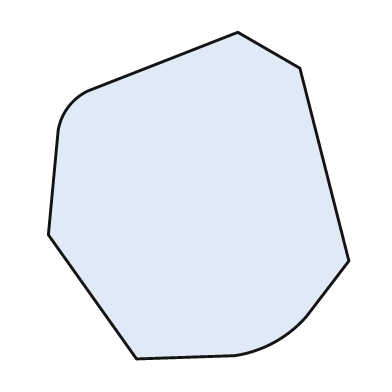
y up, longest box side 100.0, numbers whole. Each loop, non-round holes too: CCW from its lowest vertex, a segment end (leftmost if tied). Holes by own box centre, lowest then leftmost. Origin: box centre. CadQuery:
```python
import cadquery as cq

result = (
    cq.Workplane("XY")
    .moveTo(-19.0, -50.0)
    .lineTo(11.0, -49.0)
    .threePointArc((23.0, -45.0), (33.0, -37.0))
    .lineTo(46.0, -20.0)
    .lineTo(31.0, 39.0)
    .lineTo(12.0, 50.0)
    .lineTo(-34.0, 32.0)
    .threePointArc((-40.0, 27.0), (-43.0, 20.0))
    .lineTo(-46.0, -12.0)
    .close()
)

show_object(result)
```